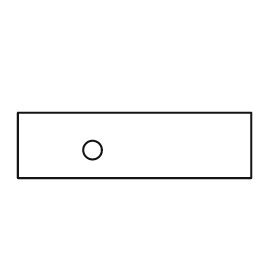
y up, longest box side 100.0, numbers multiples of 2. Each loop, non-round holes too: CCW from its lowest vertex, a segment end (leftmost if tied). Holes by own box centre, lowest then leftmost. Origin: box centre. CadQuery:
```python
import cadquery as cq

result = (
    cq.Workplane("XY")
    .moveTo(-50.0, -14.0)
    .lineTo(50.0, -14.0)
    .lineTo(50.0, 14.0)
    .lineTo(-50.0, 14.0)
    .close()
    .moveTo(-18.0, -2.0)
    .circle(4.0)
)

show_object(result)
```